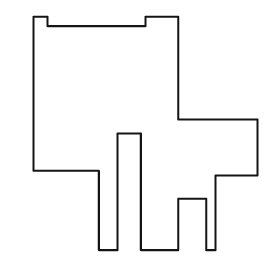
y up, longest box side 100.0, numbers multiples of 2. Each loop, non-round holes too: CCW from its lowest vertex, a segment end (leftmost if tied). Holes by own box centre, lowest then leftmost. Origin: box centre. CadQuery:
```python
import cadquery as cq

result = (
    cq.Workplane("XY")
    .moveTo(-20.0, -50.0)
    .lineTo(-12.0, -50.0)
    .lineTo(-12.0, 0.0)
    .lineTo(-2.0, 0.0)
    .lineTo(-2.0, -50.0)
    .lineTo(14.0, -50.0)
    .lineTo(14.0, -28.0)
    .lineTo(26.0, -28.0)
    .lineTo(26.0, -50.0)
    .lineTo(30.0, -50.0)
    .lineTo(30.0, -18.0)
    .lineTo(48.0, -18.0)
    .lineTo(48.0, 6.0)
    .lineTo(14.0, 6.0)
    .lineTo(14.0, 50.0)
    .lineTo(0.0, 50.0)
    .lineTo(0.0, 46.0)
    .lineTo(-42.0, 46.0)
    .lineTo(-42.0, 50.0)
    .lineTo(-48.0, 50.0)
    .lineTo(-48.0, -16.0)
    .lineTo(-20.0, -16.0)
    .close()
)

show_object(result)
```